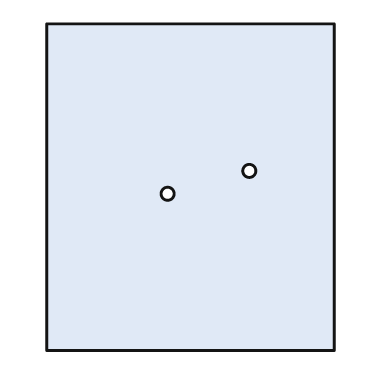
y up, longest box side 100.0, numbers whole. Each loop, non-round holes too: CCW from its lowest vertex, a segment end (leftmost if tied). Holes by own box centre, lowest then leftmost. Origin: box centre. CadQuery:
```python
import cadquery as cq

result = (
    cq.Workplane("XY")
    .moveTo(-44.0, -50.0)
    .lineTo(44.0, -50.0)
    .lineTo(44.0, 50.0)
    .lineTo(-44.0, 50.0)
    .close()
    .moveTo(-7.0, -2.0)
    .circle(2.0)
    .moveTo(18.0, 5.0)
    .circle(2.0)
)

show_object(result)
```